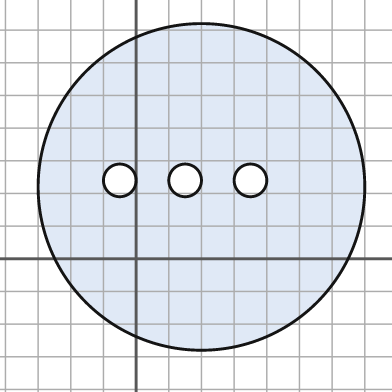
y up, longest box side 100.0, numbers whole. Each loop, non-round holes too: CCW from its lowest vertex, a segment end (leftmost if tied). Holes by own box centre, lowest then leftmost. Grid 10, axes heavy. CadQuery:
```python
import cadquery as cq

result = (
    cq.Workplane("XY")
    .moveTo(20.0, 22.0)
    .circle(50.0)
    .moveTo(-5.0, 24.0)
    .circle(5.0)
    .moveTo(15.0, 24.0)
    .circle(5.0)
    .moveTo(35.0, 24.0)
    .circle(5.0)
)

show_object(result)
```